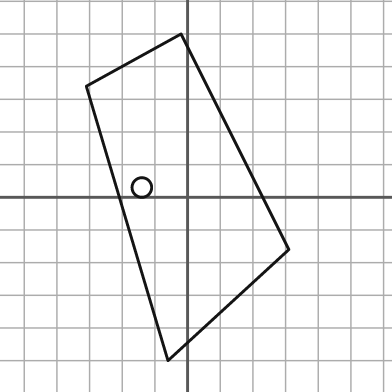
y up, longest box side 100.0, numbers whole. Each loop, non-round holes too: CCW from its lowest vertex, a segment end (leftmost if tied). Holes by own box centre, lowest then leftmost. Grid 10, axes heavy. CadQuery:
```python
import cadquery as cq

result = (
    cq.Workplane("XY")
    .moveTo(-6.0, -50.0)
    .lineTo(31.0, -16.0)
    .lineTo(-2.0, 50.0)
    .lineTo(-31.0, 34.0)
    .close()
    .moveTo(-14.0, 3.0)
    .circle(3.0)
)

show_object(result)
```